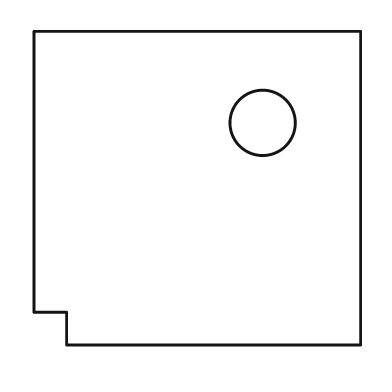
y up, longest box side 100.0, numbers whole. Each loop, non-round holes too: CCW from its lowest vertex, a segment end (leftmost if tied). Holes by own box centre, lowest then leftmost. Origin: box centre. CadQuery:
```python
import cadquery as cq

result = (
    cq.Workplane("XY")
    .moveTo(-40.0, -48.0)
    .lineTo(50.0, -48.0)
    .lineTo(50.0, 48.0)
    .lineTo(-50.0, 48.0)
    .lineTo(-50.0, -38.0)
    .lineTo(-40.0, -38.0)
    .close()
    .moveTo(20.0, 20.0)
    .circle(10.0)
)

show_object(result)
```